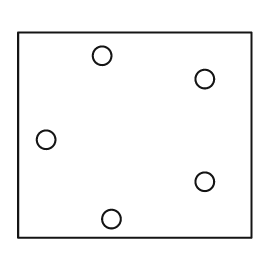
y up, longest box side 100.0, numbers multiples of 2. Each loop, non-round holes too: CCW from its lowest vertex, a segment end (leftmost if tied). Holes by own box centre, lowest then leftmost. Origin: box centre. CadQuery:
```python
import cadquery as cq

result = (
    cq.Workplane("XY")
    .moveTo(-50.0, -44.0)
    .lineTo(50.0, -44.0)
    .lineTo(50.0, 44.0)
    .lineTo(-50.0, 44.0)
    .close()
    .moveTo(-10.0, -36.0)
    .circle(4.0)
    .moveTo(30.0, -20.0)
    .circle(4.0)
    .moveTo(-38.0, -2.0)
    .circle(4.0)
    .moveTo(30.0, 24.0)
    .circle(4.0)
    .moveTo(-14.0, 34.0)
    .circle(4.0)
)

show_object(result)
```